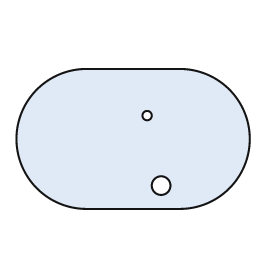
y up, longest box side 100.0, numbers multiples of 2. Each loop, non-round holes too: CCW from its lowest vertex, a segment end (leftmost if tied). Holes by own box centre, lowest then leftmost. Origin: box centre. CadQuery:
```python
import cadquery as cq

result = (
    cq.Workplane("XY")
    .moveTo(-20.0, -30.0)
    .lineTo(20.0, -30.0)
    .threePointArc((50.0, 0.0), (20.0, 30.0))
    .lineTo(-20.0, 30.0)
    .threePointArc((-50.0, 0.0), (-20.0, -30.0))
    .close()
    .moveTo(12.0, -20.0)
    .circle(4.0)
    .moveTo(6.0, 10.0)
    .circle(2.0)
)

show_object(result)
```